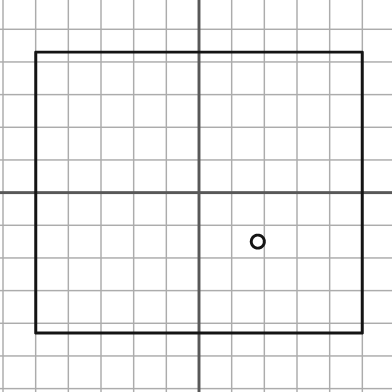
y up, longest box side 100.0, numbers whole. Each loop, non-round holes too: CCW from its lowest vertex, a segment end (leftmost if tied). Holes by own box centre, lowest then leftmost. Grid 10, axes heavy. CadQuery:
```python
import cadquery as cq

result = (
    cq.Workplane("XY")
    .moveTo(-50.0, -43.0)
    .lineTo(50.0, -43.0)
    .lineTo(50.0, 43.0)
    .lineTo(-50.0, 43.0)
    .close()
    .moveTo(18.0, -15.0)
    .circle(2.0)
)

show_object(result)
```